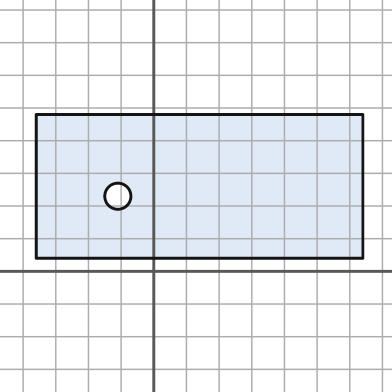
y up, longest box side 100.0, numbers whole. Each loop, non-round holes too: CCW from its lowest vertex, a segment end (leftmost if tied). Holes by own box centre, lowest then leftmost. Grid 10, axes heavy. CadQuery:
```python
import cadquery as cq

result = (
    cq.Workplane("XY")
    .moveTo(-36.0, 4.0)
    .lineTo(64.0, 4.0)
    .lineTo(64.0, 48.0)
    .lineTo(-36.0, 48.0)
    .close()
    .moveTo(-11.0, 23.0)
    .circle(4.0)
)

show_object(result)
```